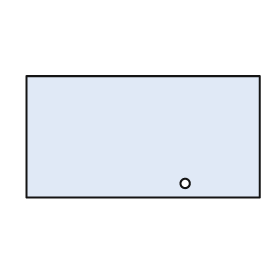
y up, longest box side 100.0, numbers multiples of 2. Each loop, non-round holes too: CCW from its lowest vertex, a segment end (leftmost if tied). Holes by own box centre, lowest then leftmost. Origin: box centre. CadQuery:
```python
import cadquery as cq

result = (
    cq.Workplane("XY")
    .moveTo(-50.0, -26.0)
    .lineTo(50.0, -26.0)
    .lineTo(50.0, 26.0)
    .lineTo(-50.0, 26.0)
    .close()
    .moveTo(18.0, -20.0)
    .circle(2.0)
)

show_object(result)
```